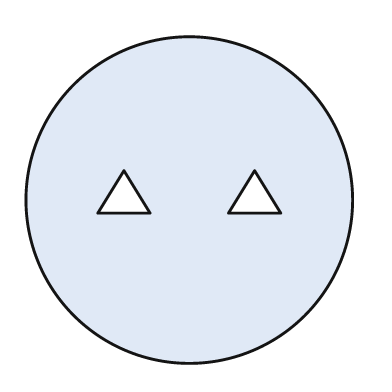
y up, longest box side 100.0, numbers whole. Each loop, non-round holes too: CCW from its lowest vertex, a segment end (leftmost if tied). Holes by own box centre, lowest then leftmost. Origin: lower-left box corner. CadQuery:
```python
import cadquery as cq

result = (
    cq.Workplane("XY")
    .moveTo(50.0, 50.0)
    .circle(50.0)
    .moveTo(22.0, 46.0)
    .lineTo(38.0, 46.0)
    .lineTo(30.0, 59.0)
    .close()
    .moveTo(62.0, 46.0)
    .lineTo(78.0, 46.0)
    .lineTo(70.0, 59.0)
    .close()
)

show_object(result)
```